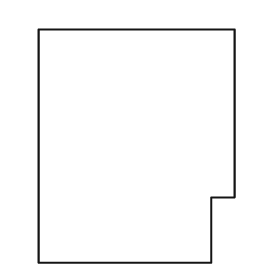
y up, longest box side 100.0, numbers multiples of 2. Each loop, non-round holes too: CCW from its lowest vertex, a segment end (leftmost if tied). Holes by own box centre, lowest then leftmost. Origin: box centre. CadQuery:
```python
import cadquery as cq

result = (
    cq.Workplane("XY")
    .moveTo(-42.0, -50.0)
    .lineTo(32.0, -50.0)
    .lineTo(32.0, -22.0)
    .lineTo(42.0, -22.0)
    .lineTo(42.0, 50.0)
    .lineTo(-42.0, 50.0)
    .close()
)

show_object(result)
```